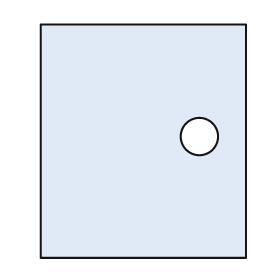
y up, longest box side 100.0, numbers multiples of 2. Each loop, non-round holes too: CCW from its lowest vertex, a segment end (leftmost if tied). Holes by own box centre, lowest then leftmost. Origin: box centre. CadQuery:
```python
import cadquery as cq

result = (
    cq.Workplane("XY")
    .moveTo(-44.0, -50.0)
    .lineTo(44.0, -50.0)
    .lineTo(44.0, 50.0)
    .lineTo(-44.0, 50.0)
    .close()
    .moveTo(24.0, 2.0)
    .circle(8.0)
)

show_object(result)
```